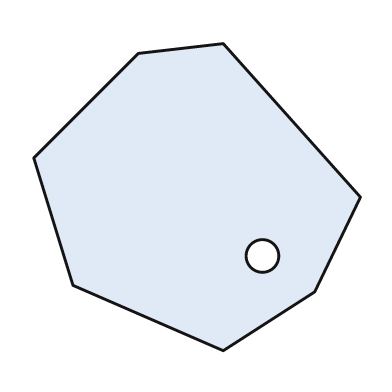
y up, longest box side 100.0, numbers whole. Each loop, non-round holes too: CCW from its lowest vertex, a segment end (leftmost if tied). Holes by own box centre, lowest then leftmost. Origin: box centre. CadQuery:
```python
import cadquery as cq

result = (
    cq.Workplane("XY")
    .moveTo(8.0, -47.0)
    .lineTo(36.0, -29.0)
    .lineTo(50.0, 0.0)
    .lineTo(8.0, 47.0)
    .lineTo(-18.0, 44.0)
    .lineTo(-50.0, 12.0)
    .lineTo(-38.0, -27.0)
    .close()
    .moveTo(20.0, -18.0)
    .circle(5.0)
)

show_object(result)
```